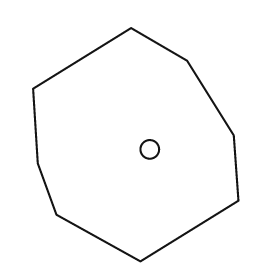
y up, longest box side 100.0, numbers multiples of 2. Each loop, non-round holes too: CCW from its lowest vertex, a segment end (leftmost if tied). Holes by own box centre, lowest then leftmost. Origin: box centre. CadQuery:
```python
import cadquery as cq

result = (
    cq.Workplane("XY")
    .moveTo(2.0, -50.0)
    .lineTo(44.0, -24.0)
    .lineTo(42.0, 4.0)
    .lineTo(22.0, 36.0)
    .lineTo(-2.0, 50.0)
    .lineTo(-44.0, 24.0)
    .lineTo(-42.0, -8.0)
    .lineTo(-34.0, -30.0)
    .close()
    .moveTo(6.0, -2.0)
    .circle(4.0)
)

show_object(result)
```